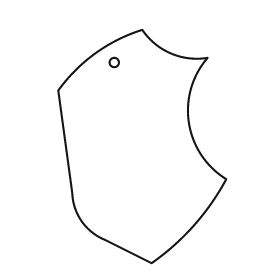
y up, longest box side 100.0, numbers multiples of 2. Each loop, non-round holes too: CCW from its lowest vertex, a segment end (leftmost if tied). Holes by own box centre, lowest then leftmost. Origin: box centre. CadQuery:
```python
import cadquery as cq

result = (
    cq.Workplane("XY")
    .moveTo(4.0, -50.0)
    .threePointArc((22.0, -34.0), (36.0, -14.0))
    .threePointArc((20.0, 10.0), (28.0, 38.0))
    .threePointArc((12.0, 40.0), (0.0, 50.0))
    .threePointArc((-20.0, 40.0), (-36.0, 24.0))
    .lineTo(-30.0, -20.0)
    .threePointArc((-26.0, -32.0), (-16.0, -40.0))
    .close()
    .moveTo(-12.0, 36.0)
    .circle(2.0)
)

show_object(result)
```